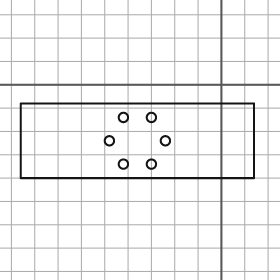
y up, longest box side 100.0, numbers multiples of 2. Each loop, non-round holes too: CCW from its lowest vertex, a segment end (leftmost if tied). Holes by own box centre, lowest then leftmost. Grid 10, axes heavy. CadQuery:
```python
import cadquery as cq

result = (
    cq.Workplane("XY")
    .moveTo(-86.0, -40.0)
    .lineTo(14.0, -40.0)
    .lineTo(14.0, -8.0)
    .lineTo(-86.0, -8.0)
    .close()
    .moveTo(-42.0, -34.0)
    .circle(2.0)
    .moveTo(-30.0, -34.0)
    .circle(2.0)
    .moveTo(-48.0, -24.0)
    .circle(2.0)
    .moveTo(-24.0, -24.0)
    .circle(2.0)
    .moveTo(-42.0, -14.0)
    .circle(2.0)
    .moveTo(-30.0, -14.0)
    .circle(2.0)
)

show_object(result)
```